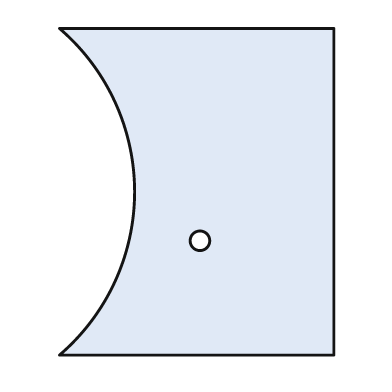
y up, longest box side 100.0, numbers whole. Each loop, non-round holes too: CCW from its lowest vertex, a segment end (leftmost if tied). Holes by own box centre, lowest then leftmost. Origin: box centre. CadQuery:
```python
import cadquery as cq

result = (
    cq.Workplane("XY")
    .moveTo(-42.0, -50.0)
    .lineTo(42.0, -50.0)
    .lineTo(42.0, 50.0)
    .lineTo(-42.0, 50.0)
    .threePointArc((-19.0, 0.0), (-42.0, -50.0))
    .close()
    .moveTo(1.0, -15.0)
    .circle(3.0)
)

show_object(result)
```